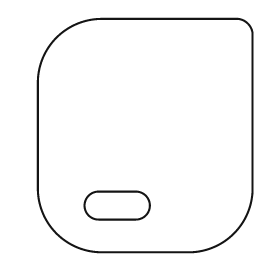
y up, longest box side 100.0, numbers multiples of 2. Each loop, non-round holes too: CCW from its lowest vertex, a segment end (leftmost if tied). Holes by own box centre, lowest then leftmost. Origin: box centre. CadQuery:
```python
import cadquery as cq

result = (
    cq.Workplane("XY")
    .moveTo(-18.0, -50.0)
    .lineTo(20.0, -50.0)
    .threePointArc((38.0, -42.0), (46.0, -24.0))
    .lineTo(46.0, 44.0)
    .threePointArc((44.0, 48.0), (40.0, 50.0))
    .lineTo(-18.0, 50.0)
    .threePointArc((-38.0, 42.0), (-46.0, 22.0))
    .lineTo(-46.0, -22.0)
    .threePointArc((-38.0, -42.0), (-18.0, -50.0))
    .close()
    .moveTo(-20.0, -36.0)
    .lineTo(-4.0, -36.0)
    .threePointArc((2.0, -30.0), (-4.0, -24.0))
    .lineTo(-20.0, -24.0)
    .threePointArc((-26.0, -30.0), (-20.0, -36.0))
    .close()
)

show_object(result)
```